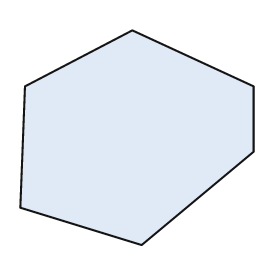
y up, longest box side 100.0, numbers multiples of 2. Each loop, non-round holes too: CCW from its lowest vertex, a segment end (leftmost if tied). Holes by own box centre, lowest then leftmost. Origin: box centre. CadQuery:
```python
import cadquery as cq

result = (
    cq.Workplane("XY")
    .moveTo(2.0, -46.0)
    .lineTo(50.0, -6.0)
    .lineTo(50.0, 22.0)
    .lineTo(-2.0, 46.0)
    .lineTo(-48.0, 22.0)
    .lineTo(-50.0, -30.0)
    .close()
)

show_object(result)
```